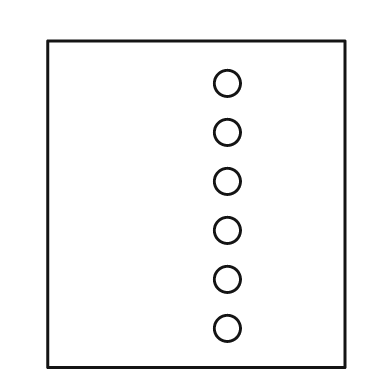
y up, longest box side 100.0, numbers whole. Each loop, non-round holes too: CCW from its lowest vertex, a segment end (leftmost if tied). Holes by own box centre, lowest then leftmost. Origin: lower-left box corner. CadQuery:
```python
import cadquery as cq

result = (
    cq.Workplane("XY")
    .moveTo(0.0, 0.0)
    .lineTo(91.0, 0.0)
    .lineTo(91.0, 100.0)
    .lineTo(0.0, 100.0)
    .close()
    .moveTo(55.0, 12.0)
    .circle(4.0)
    .moveTo(55.0, 27.0)
    .circle(4.0)
    .moveTo(55.0, 42.0)
    .circle(4.0)
    .moveTo(55.0, 57.0)
    .circle(4.0)
    .moveTo(55.0, 72.0)
    .circle(4.0)
    .moveTo(55.0, 87.0)
    .circle(4.0)
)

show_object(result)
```